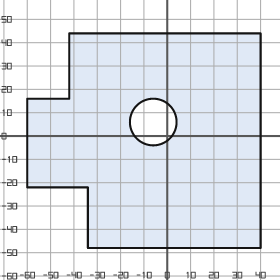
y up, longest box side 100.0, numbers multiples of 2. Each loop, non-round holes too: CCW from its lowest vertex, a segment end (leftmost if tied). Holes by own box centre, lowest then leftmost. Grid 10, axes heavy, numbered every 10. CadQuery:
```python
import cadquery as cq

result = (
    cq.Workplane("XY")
    .moveTo(-34.0, -48.0)
    .lineTo(40.0, -48.0)
    .lineTo(40.0, 44.0)
    .lineTo(-42.0, 44.0)
    .lineTo(-42.0, 16.0)
    .lineTo(-60.0, 16.0)
    .lineTo(-60.0, -22.0)
    .lineTo(-34.0, -22.0)
    .close()
    .moveTo(-6.0, 6.0)
    .circle(10.0)
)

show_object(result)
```